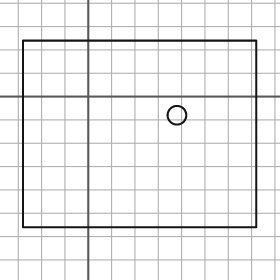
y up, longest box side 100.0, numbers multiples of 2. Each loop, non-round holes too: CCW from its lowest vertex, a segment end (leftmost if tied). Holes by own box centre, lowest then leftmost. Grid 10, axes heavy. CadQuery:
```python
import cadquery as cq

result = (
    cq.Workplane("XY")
    .moveTo(-28.0, -56.0)
    .lineTo(72.0, -56.0)
    .lineTo(72.0, 24.0)
    .lineTo(-28.0, 24.0)
    .close()
    .moveTo(38.0, -8.0)
    .circle(4.0)
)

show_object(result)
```